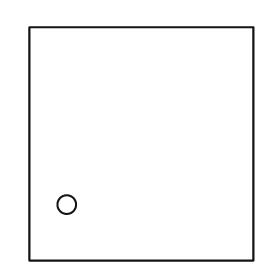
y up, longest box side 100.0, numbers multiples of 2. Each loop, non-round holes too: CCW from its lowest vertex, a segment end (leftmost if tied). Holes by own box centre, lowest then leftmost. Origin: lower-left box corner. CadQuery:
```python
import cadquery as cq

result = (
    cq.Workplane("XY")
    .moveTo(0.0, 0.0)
    .lineTo(96.0, 0.0)
    .lineTo(96.0, 100.0)
    .lineTo(0.0, 100.0)
    .close()
    .moveTo(16.0, 24.0)
    .circle(4.0)
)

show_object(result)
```